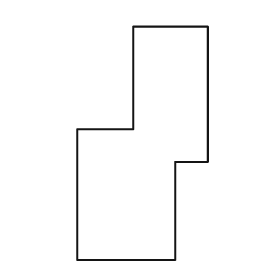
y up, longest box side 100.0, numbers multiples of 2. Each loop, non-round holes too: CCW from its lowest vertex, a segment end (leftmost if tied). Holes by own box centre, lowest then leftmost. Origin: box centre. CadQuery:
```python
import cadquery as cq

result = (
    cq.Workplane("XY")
    .moveTo(-28.0, -50.0)
    .lineTo(14.0, -50.0)
    .lineTo(14.0, -8.0)
    .lineTo(28.0, -8.0)
    .lineTo(28.0, 50.0)
    .lineTo(-4.0, 50.0)
    .lineTo(-4.0, 6.0)
    .lineTo(-28.0, 6.0)
    .close()
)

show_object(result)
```